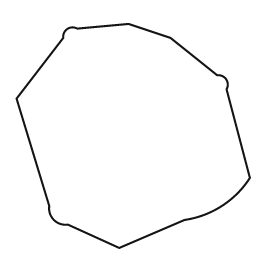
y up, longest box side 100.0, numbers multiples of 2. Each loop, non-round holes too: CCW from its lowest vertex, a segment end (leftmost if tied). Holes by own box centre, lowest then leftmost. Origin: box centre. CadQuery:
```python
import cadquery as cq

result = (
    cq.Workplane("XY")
    .moveTo(-6.0, -48.0)
    .lineTo(22.0, -36.0)
    .threePointArc((38.0, -30.0), (50.0, -18.0))
    .lineTo(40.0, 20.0)
    .threePointArc((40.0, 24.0), (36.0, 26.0))
    .lineTo(16.0, 42.0)
    .lineTo(-2.0, 48.0)
    .lineTo(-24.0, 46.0)
    .threePointArc((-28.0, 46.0), (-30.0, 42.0))
    .lineTo(-50.0, 16.0)
    .lineTo(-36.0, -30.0)
    .threePointArc((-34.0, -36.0), (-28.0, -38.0))
    .close()
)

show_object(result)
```